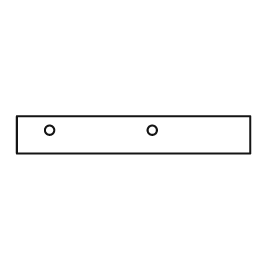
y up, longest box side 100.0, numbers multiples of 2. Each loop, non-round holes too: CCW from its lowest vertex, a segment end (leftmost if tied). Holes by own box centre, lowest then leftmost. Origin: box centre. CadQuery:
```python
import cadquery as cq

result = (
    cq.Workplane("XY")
    .moveTo(-50.0, -8.0)
    .lineTo(50.0, -8.0)
    .lineTo(50.0, 8.0)
    .lineTo(-50.0, 8.0)
    .close()
    .moveTo(-36.0, 2.0)
    .circle(2.0)
    .moveTo(8.0, 2.0)
    .circle(2.0)
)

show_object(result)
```